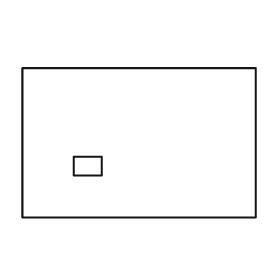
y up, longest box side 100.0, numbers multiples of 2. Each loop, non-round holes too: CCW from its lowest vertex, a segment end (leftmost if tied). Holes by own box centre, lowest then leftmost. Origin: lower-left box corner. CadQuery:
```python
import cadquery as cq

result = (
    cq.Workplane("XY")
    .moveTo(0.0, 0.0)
    .lineTo(100.0, 0.0)
    .lineTo(100.0, 64.0)
    .lineTo(0.0, 64.0)
    .close()
    .moveTo(22.0, 18.0)
    .lineTo(34.0, 18.0)
    .lineTo(34.0, 26.0)
    .lineTo(22.0, 26.0)
    .close()
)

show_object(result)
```